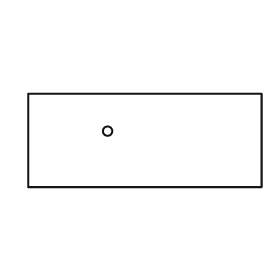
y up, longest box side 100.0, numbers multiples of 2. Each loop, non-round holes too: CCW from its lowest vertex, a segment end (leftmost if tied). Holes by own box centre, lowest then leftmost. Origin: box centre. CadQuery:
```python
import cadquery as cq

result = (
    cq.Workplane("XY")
    .moveTo(-50.0, -20.0)
    .lineTo(50.0, -20.0)
    .lineTo(50.0, 20.0)
    .lineTo(-50.0, 20.0)
    .close()
    .moveTo(-16.0, 4.0)
    .circle(2.0)
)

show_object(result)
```